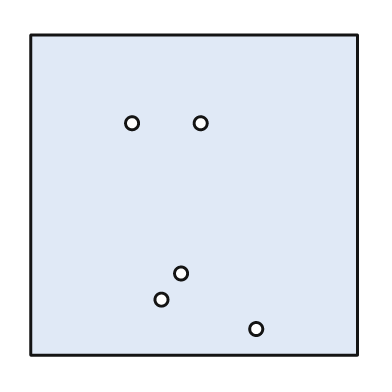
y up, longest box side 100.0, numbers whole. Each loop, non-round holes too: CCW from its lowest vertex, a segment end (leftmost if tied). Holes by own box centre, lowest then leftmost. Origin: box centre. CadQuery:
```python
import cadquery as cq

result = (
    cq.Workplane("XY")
    .moveTo(-50.0, -49.0)
    .lineTo(50.0, -49.0)
    .lineTo(50.0, 49.0)
    .lineTo(-50.0, 49.0)
    .close()
    .moveTo(19.0, -41.0)
    .circle(2.0)
    .moveTo(-10.0, -32.0)
    .circle(2.0)
    .moveTo(-4.0, -24.0)
    .circle(2.0)
    .moveTo(-19.0, 22.0)
    .circle(2.0)
    .moveTo(2.0, 22.0)
    .circle(2.0)
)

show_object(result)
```